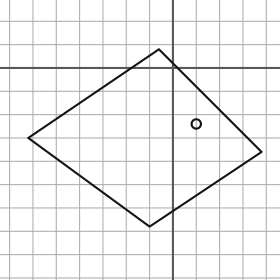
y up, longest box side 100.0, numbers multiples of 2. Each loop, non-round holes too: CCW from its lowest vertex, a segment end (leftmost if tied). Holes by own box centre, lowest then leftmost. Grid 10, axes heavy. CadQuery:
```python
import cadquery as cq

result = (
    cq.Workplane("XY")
    .moveTo(-10.0, -68.0)
    .lineTo(38.0, -36.0)
    .lineTo(-6.0, 8.0)
    .lineTo(-62.0, -30.0)
    .close()
    .moveTo(10.0, -24.0)
    .circle(2.0)
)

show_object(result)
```